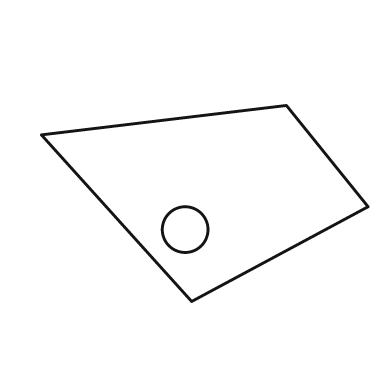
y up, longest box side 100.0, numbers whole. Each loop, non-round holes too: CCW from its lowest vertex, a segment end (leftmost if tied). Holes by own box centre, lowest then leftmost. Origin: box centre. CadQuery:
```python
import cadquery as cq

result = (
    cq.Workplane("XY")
    .moveTo(-4.0, -30.0)
    .lineTo(50.0, -1.0)
    .lineTo(25.0, 30.0)
    .lineTo(-50.0, 21.0)
    .close()
    .moveTo(-6.0, -8.0)
    .circle(7.0)
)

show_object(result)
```